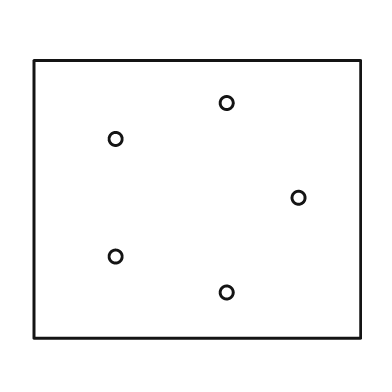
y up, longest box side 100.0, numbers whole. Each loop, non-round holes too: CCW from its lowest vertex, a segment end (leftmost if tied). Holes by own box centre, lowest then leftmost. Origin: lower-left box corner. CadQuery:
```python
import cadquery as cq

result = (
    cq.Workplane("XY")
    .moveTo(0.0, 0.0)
    .lineTo(100.0, 0.0)
    .lineTo(100.0, 85.0)
    .lineTo(0.0, 85.0)
    .close()
    .moveTo(59.0, 14.0)
    .circle(2.0)
    .moveTo(25.0, 25.0)
    .circle(2.0)
    .moveTo(81.0, 43.0)
    .circle(2.0)
    .moveTo(25.0, 61.0)
    .circle(2.0)
    .moveTo(59.0, 72.0)
    .circle(2.0)
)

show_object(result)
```